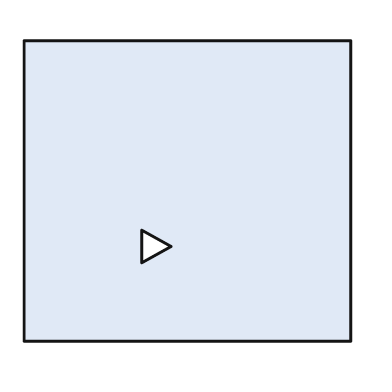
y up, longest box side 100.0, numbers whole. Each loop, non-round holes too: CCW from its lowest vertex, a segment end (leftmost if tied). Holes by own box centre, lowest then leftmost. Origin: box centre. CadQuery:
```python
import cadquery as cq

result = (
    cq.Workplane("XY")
    .moveTo(-50.0, -46.0)
    .lineTo(50.0, -46.0)
    .lineTo(50.0, 46.0)
    .lineTo(-50.0, 46.0)
    .close()
    .moveTo(-14.0, -22.0)
    .lineTo(-5.0, -17.0)
    .lineTo(-14.0, -12.0)
    .close()
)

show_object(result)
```